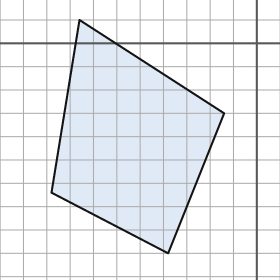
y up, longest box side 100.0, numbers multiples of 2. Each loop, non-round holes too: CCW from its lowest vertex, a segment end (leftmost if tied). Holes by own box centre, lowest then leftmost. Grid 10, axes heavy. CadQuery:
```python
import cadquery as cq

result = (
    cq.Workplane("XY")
    .moveTo(-38.0, -90.0)
    .lineTo(-14.0, -30.0)
    .lineTo(-76.0, 10.0)
    .lineTo(-88.0, -64.0)
    .close()
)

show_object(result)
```